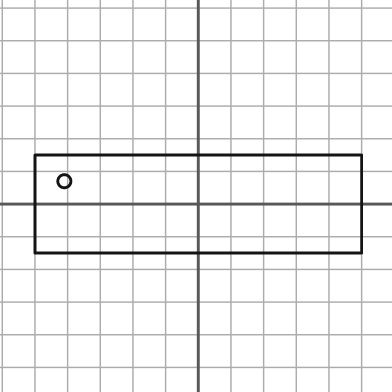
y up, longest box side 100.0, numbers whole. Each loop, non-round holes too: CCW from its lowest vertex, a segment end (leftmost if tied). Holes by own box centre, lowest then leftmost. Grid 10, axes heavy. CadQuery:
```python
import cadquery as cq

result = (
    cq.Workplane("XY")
    .moveTo(-50.0, -15.0)
    .lineTo(50.0, -15.0)
    .lineTo(50.0, 15.0)
    .lineTo(-50.0, 15.0)
    .close()
    .moveTo(-41.0, 7.0)
    .circle(2.0)
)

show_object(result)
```